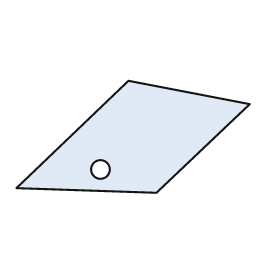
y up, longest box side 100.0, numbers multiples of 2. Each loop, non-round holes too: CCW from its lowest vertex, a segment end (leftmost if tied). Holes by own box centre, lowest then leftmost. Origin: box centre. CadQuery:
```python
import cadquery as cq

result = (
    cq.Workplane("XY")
    .moveTo(10.0, -24.0)
    .lineTo(50.0, 14.0)
    .lineTo(-2.0, 24.0)
    .lineTo(-50.0, -22.0)
    .close()
    .moveTo(-14.0, -14.0)
    .circle(4.0)
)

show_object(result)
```